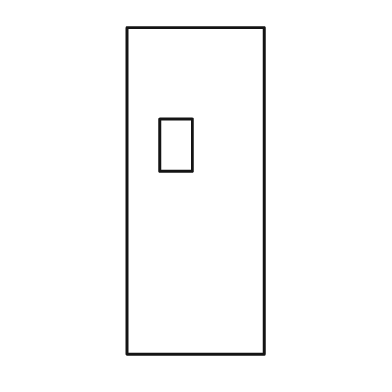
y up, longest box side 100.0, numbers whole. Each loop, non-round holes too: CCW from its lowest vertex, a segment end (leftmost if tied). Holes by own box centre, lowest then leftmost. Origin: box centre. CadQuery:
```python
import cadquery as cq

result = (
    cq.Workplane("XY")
    .moveTo(-21.0, -50.0)
    .lineTo(21.0, -50.0)
    .lineTo(21.0, 50.0)
    .lineTo(-21.0, 50.0)
    .close()
    .moveTo(-11.0, 6.0)
    .lineTo(-1.0, 6.0)
    .lineTo(-1.0, 22.0)
    .lineTo(-11.0, 22.0)
    .close()
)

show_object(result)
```